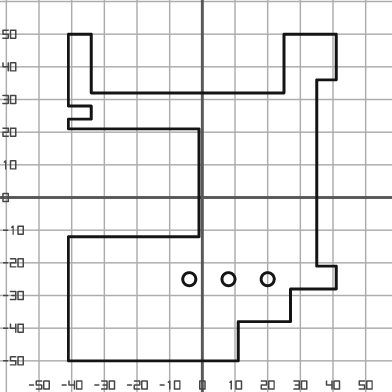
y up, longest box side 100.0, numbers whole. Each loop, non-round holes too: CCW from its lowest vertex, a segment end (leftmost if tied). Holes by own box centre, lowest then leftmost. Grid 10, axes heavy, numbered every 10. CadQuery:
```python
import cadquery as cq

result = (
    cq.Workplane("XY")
    .moveTo(-41.0, -50.0)
    .lineTo(11.0, -50.0)
    .lineTo(11.0, -38.0)
    .lineTo(27.0, -38.0)
    .lineTo(27.0, -28.0)
    .lineTo(41.0, -28.0)
    .lineTo(41.0, -21.0)
    .lineTo(35.0, -21.0)
    .lineTo(35.0, 36.0)
    .lineTo(41.0, 36.0)
    .lineTo(41.0, 50.0)
    .lineTo(25.0, 50.0)
    .lineTo(25.0, 32.0)
    .lineTo(-34.0, 32.0)
    .lineTo(-34.0, 50.0)
    .lineTo(-41.0, 50.0)
    .lineTo(-41.0, 28.0)
    .lineTo(-34.0, 28.0)
    .lineTo(-34.0, 24.0)
    .lineTo(-41.0, 24.0)
    .lineTo(-41.0, 21.0)
    .lineTo(-1.0, 21.0)
    .lineTo(-1.0, -12.0)
    .lineTo(-41.0, -12.0)
    .close()
    .moveTo(-4.0, -25.0)
    .circle(2.0)
    .moveTo(8.0, -25.0)
    .circle(2.0)
    .moveTo(20.0, -25.0)
    .circle(2.0)
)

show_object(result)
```